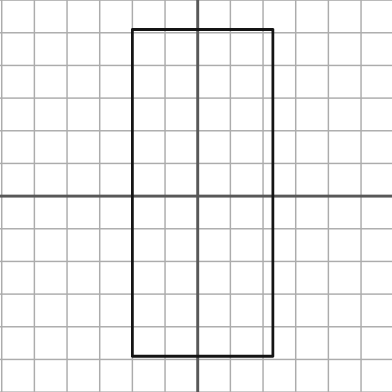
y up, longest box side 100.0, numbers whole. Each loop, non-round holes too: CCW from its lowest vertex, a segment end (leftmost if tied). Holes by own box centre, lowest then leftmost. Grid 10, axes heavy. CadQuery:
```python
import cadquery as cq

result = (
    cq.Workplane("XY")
    .moveTo(-20.0, -49.0)
    .lineTo(23.0, -49.0)
    .lineTo(23.0, 51.0)
    .lineTo(-20.0, 51.0)
    .close()
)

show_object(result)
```